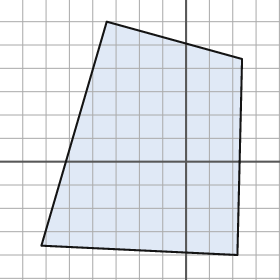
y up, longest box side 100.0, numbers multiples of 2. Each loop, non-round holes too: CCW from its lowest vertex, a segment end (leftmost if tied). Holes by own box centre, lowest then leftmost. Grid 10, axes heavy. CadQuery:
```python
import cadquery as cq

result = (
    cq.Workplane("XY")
    .moveTo(22.0, -40.0)
    .lineTo(24.0, 44.0)
    .lineTo(-34.0, 60.0)
    .lineTo(-62.0, -36.0)
    .close()
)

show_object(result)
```